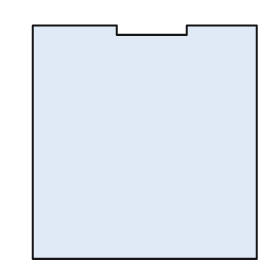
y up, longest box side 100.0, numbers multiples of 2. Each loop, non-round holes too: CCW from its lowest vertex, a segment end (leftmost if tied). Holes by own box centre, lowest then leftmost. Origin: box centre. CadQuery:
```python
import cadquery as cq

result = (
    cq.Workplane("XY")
    .moveTo(-48.0, -50.0)
    .lineTo(48.0, -50.0)
    .lineTo(48.0, 50.0)
    .lineTo(18.0, 50.0)
    .lineTo(18.0, 46.0)
    .lineTo(-12.0, 46.0)
    .lineTo(-12.0, 50.0)
    .lineTo(-48.0, 50.0)
    .close()
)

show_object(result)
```